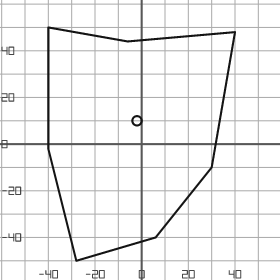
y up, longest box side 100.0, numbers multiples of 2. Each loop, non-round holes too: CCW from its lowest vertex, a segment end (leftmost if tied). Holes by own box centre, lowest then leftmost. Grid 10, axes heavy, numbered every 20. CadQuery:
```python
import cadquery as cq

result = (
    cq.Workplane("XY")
    .moveTo(-28.0, -50.0)
    .lineTo(6.0, -40.0)
    .lineTo(30.0, -10.0)
    .lineTo(40.0, 48.0)
    .lineTo(-6.0, 44.0)
    .lineTo(-40.0, 50.0)
    .lineTo(-40.0, -2.0)
    .close()
    .moveTo(-2.0, 10.0)
    .circle(2.0)
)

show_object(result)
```